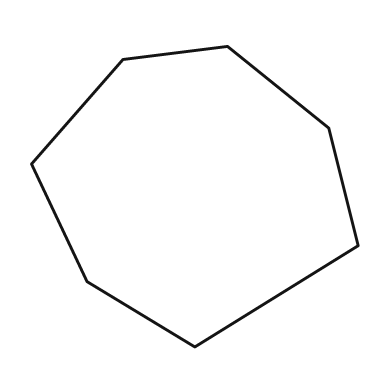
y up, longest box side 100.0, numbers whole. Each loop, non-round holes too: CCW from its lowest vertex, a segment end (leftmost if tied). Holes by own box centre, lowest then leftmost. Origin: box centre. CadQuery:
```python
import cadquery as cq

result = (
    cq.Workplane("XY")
    .moveTo(0.0, -46.0)
    .lineTo(50.0, -15.0)
    .lineTo(41.0, 21.0)
    .lineTo(10.0, 46.0)
    .lineTo(-22.0, 42.0)
    .lineTo(-50.0, 10.0)
    .lineTo(-33.0, -26.0)
    .close()
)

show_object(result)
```